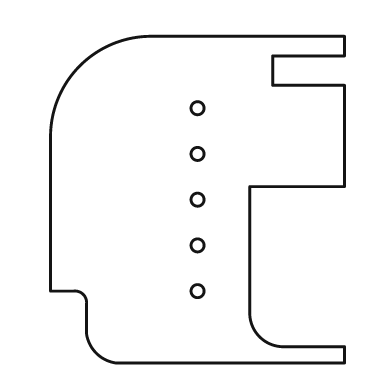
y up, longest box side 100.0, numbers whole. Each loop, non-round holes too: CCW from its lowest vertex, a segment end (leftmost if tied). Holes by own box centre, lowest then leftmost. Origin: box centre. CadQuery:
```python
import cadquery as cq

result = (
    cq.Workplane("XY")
    .moveTo(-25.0, -50.0)
    .lineTo(45.0, -50.0)
    .lineTo(45.0, -45.0)
    .lineTo(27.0, -45.0)
    .threePointArc((19.0, -42.0), (16.0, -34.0))
    .lineTo(16.0, 4.0)
    .lineTo(45.0, 4.0)
    .lineTo(45.0, 35.0)
    .lineTo(23.0, 35.0)
    .lineTo(23.0, 44.0)
    .lineTo(45.0, 44.0)
    .lineTo(45.0, 50.0)
    .lineTo(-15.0, 50.0)
    .threePointArc((-36.0, 41.0), (-45.0, 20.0))
    .lineTo(-45.0, -28.0)
    .lineTo(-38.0, -28.0)
    .threePointArc((-35.0, -29.0), (-34.0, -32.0))
    .lineTo(-34.0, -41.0)
    .threePointArc((-31.0, -47.0), (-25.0, -50.0))
    .close()
    .moveTo(0.0, -28.0)
    .circle(2.0)
    .moveTo(0.0, -14.0)
    .circle(2.0)
    .moveTo(0.0, 0.0)
    .circle(2.0)
    .moveTo(0.0, 14.0)
    .circle(2.0)
    .moveTo(0.0, 28.0)
    .circle(2.0)
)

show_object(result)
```